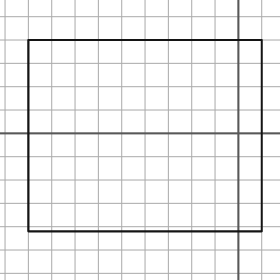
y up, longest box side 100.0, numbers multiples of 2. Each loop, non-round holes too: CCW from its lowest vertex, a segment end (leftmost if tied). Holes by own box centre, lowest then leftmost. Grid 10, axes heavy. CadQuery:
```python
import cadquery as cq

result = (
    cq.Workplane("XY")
    .moveTo(-90.0, -42.0)
    .lineTo(10.0, -42.0)
    .lineTo(10.0, 40.0)
    .lineTo(-90.0, 40.0)
    .close()
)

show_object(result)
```